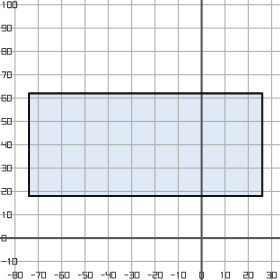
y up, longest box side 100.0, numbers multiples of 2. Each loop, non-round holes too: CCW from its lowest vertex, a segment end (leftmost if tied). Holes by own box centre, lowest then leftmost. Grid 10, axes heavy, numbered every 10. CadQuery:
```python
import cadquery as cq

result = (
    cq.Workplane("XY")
    .moveTo(-74.0, 18.0)
    .lineTo(26.0, 18.0)
    .lineTo(26.0, 62.0)
    .lineTo(-74.0, 62.0)
    .close()
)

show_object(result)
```